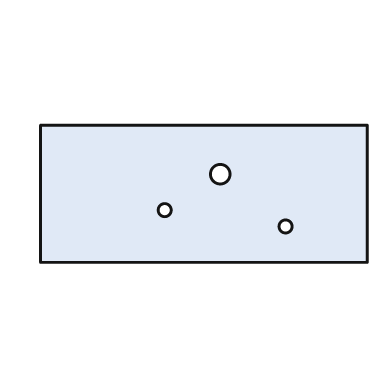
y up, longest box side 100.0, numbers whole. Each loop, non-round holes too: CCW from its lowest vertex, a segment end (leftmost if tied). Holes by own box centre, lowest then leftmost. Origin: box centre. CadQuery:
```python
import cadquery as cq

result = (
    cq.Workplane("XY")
    .moveTo(-50.0, -21.0)
    .lineTo(50.0, -21.0)
    .lineTo(50.0, 21.0)
    .lineTo(-50.0, 21.0)
    .close()
    .moveTo(25.0, -10.0)
    .circle(2.0)
    .moveTo(-12.0, -5.0)
    .circle(2.0)
    .moveTo(5.0, 6.0)
    .circle(3.0)
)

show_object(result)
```